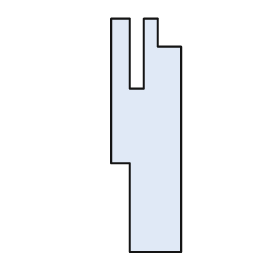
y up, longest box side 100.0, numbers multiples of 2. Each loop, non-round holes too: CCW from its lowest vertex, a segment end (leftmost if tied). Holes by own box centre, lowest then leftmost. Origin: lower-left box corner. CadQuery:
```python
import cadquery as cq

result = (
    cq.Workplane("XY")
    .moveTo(8.0, 0.0)
    .lineTo(30.0, 0.0)
    .lineTo(30.0, 88.0)
    .lineTo(20.0, 88.0)
    .lineTo(20.0, 100.0)
    .lineTo(14.0, 100.0)
    .lineTo(14.0, 70.0)
    .lineTo(8.0, 70.0)
    .lineTo(8.0, 100.0)
    .lineTo(0.0, 100.0)
    .lineTo(0.0, 38.0)
    .lineTo(8.0, 38.0)
    .close()
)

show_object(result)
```